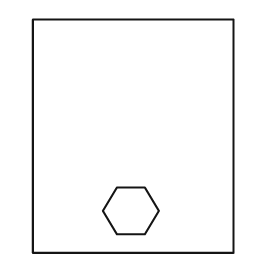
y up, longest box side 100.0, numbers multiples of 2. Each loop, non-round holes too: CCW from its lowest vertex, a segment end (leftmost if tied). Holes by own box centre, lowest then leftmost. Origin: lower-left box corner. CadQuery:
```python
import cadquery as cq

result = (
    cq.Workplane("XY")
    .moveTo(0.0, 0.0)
    .lineTo(86.0, 0.0)
    .lineTo(86.0, 100.0)
    .lineTo(0.0, 100.0)
    .close()
    .moveTo(36.0, 8.0)
    .lineTo(48.0, 8.0)
    .lineTo(54.0, 18.0)
    .lineTo(48.0, 28.0)
    .lineTo(36.0, 28.0)
    .lineTo(30.0, 18.0)
    .close()
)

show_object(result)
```